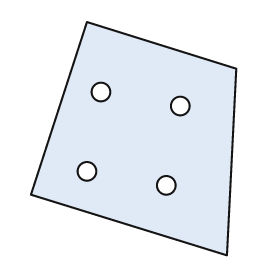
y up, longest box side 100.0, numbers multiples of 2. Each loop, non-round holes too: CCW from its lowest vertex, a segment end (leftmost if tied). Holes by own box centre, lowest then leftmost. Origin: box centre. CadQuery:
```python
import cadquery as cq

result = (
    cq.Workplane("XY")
    .moveTo(40.0, -50.0)
    .lineTo(44.0, 30.0)
    .lineTo(-20.0, 50.0)
    .lineTo(-44.0, -24.0)
    .close()
    .moveTo(14.0, -20.0)
    .circle(4.0)
    .moveTo(-20.0, -14.0)
    .circle(4.0)
    .moveTo(20.0, 14.0)
    .circle(4.0)
    .moveTo(-14.0, 20.0)
    .circle(4.0)
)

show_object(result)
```